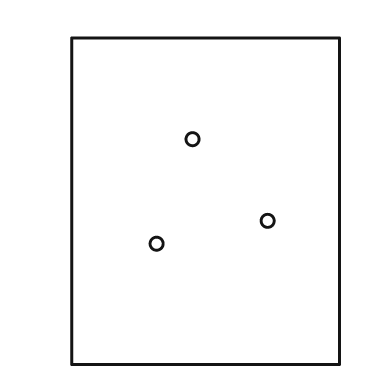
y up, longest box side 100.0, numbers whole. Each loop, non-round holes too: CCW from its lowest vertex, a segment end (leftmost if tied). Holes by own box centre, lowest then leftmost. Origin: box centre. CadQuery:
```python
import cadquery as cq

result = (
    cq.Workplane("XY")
    .moveTo(-41.0, -50.0)
    .lineTo(41.0, -50.0)
    .lineTo(41.0, 50.0)
    .lineTo(-41.0, 50.0)
    .close()
    .moveTo(-15.0, -13.0)
    .circle(2.0)
    .moveTo(19.0, -6.0)
    .circle(2.0)
    .moveTo(-4.0, 19.0)
    .circle(2.0)
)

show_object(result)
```